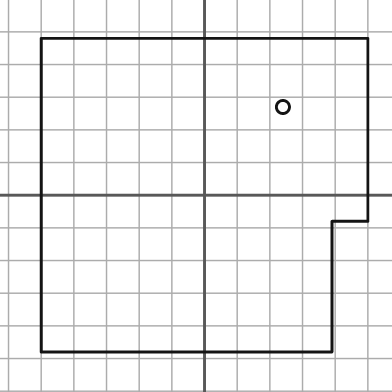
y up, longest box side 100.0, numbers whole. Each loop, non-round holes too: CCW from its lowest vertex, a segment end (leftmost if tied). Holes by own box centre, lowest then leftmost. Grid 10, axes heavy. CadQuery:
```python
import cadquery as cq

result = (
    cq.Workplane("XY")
    .moveTo(-50.0, -48.0)
    .lineTo(39.0, -48.0)
    .lineTo(39.0, -8.0)
    .lineTo(50.0, -8.0)
    .lineTo(50.0, 48.0)
    .lineTo(-50.0, 48.0)
    .close()
    .moveTo(24.0, 27.0)
    .circle(2.0)
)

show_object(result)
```